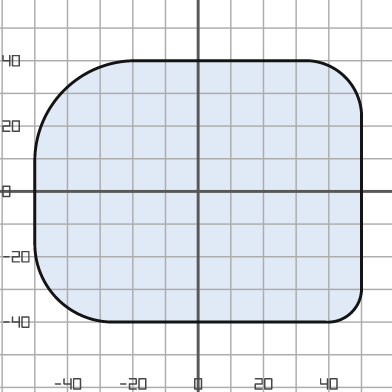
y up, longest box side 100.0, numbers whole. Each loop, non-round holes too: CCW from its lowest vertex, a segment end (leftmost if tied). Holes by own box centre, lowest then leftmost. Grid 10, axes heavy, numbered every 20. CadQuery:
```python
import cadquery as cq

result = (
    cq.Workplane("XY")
    .moveTo(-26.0, -40.0)
    .lineTo(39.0, -40.0)
    .threePointArc((47.0, -37.0), (50.0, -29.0))
    .lineTo(50.0, 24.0)
    .threePointArc((45.0, 35.0), (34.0, 40.0))
    .lineTo(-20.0, 40.0)
    .threePointArc((-41.0, 31.0), (-50.0, 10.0))
    .lineTo(-50.0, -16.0)
    .threePointArc((-43.0, -33.0), (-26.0, -40.0))
    .close()
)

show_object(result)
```